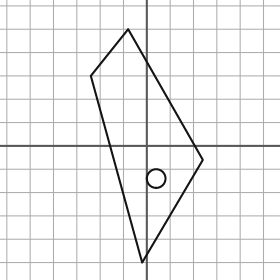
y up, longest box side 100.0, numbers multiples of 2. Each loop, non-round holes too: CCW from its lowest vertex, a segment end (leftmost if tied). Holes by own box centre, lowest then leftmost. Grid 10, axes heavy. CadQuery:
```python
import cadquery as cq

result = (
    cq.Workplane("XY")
    .moveTo(-2.0, -50.0)
    .lineTo(24.0, -6.0)
    .lineTo(-8.0, 50.0)
    .lineTo(-24.0, 30.0)
    .close()
    .moveTo(4.0, -14.0)
    .circle(4.0)
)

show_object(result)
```